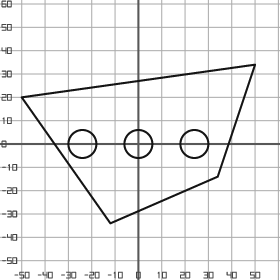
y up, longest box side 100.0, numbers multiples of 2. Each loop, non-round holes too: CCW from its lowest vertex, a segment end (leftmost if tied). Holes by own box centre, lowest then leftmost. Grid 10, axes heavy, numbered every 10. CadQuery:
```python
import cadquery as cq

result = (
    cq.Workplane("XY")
    .moveTo(-12.0, -34.0)
    .lineTo(34.0, -14.0)
    .lineTo(50.0, 34.0)
    .lineTo(-50.0, 20.0)
    .close()
    .moveTo(-24.0, 0.0)
    .circle(6.0)
    .moveTo(0.0, 0.0)
    .circle(6.0)
    .moveTo(24.0, 0.0)
    .circle(6.0)
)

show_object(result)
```